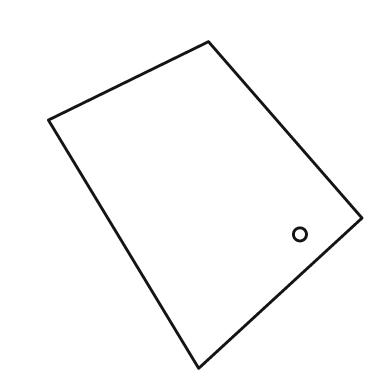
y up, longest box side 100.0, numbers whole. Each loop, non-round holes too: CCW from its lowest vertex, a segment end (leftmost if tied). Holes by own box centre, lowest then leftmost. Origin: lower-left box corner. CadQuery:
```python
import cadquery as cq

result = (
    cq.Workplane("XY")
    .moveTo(46.0, 0.0)
    .lineTo(96.0, 46.0)
    .lineTo(49.0, 100.0)
    .lineTo(0.0, 76.0)
    .close()
    .moveTo(77.0, 41.0)
    .circle(2.0)
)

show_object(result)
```